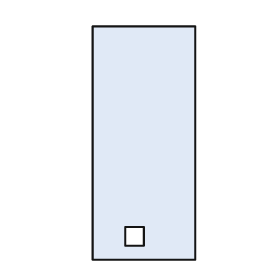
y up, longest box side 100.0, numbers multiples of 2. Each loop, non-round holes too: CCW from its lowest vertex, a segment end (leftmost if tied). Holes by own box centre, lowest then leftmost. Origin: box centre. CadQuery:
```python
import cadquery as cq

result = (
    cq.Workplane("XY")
    .moveTo(-22.0, -50.0)
    .lineTo(22.0, -50.0)
    .lineTo(22.0, 50.0)
    .lineTo(-22.0, 50.0)
    .close()
    .moveTo(-8.0, -44.0)
    .lineTo(0.0, -44.0)
    .lineTo(0.0, -36.0)
    .lineTo(-8.0, -36.0)
    .close()
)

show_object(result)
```